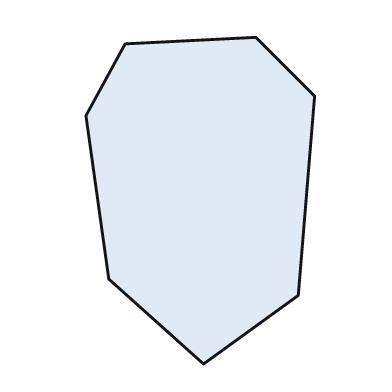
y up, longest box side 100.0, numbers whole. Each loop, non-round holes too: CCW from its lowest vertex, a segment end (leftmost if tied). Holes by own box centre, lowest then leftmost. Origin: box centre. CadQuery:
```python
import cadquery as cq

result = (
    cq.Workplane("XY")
    .moveTo(1.0, -50.0)
    .lineTo(30.0, -29.0)
    .lineTo(35.0, 32.0)
    .lineTo(17.0, 50.0)
    .lineTo(-23.0, 48.0)
    .lineTo(-35.0, 26.0)
    .lineTo(-28.0, -24.0)
    .close()
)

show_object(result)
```